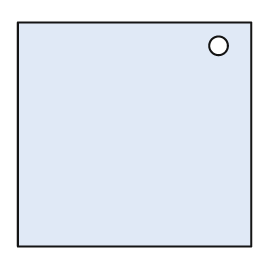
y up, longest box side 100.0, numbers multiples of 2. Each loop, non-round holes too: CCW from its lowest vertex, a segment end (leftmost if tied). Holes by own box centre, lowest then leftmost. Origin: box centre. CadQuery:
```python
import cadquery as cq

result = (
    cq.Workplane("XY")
    .moveTo(-50.0, -48.0)
    .lineTo(50.0, -48.0)
    .lineTo(50.0, 48.0)
    .lineTo(-50.0, 48.0)
    .close()
    .moveTo(36.0, 38.0)
    .circle(4.0)
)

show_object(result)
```